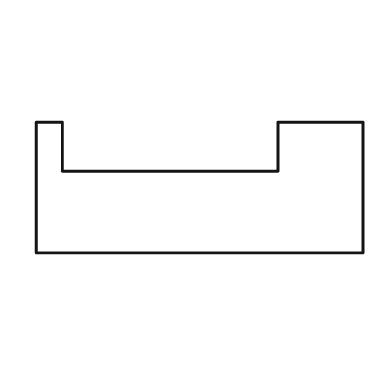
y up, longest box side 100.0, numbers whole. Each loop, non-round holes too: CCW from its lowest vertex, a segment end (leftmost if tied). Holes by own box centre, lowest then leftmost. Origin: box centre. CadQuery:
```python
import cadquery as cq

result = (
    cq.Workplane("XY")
    .moveTo(-50.0, -20.0)
    .lineTo(50.0, -20.0)
    .lineTo(50.0, 20.0)
    .lineTo(24.0, 20.0)
    .lineTo(24.0, 5.0)
    .lineTo(-42.0, 5.0)
    .lineTo(-42.0, 20.0)
    .lineTo(-50.0, 20.0)
    .close()
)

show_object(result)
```